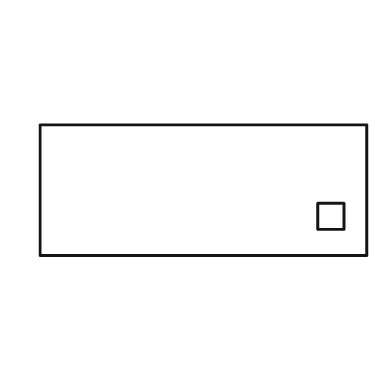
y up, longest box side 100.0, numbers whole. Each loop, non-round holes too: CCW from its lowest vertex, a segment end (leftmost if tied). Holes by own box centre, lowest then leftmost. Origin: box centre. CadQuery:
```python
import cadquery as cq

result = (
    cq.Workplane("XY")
    .moveTo(-50.0, -20.0)
    .lineTo(50.0, -20.0)
    .lineTo(50.0, 20.0)
    .lineTo(-50.0, 20.0)
    .close()
    .moveTo(35.0, -12.0)
    .lineTo(43.0, -12.0)
    .lineTo(43.0, -4.0)
    .lineTo(35.0, -4.0)
    .close()
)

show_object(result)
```